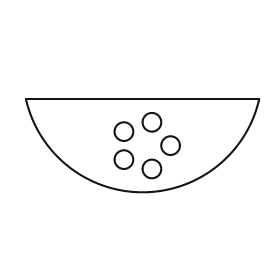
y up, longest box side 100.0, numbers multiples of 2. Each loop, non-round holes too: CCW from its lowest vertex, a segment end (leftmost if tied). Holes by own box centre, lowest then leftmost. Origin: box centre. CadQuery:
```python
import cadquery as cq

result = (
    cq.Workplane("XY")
    .moveTo(-50.0, 20.0)
    .threePointArc((0.0, -20.0), (50.0, 20.0))
    .close()
    .moveTo(4.0, -10.0)
    .circle(4.0)
    .moveTo(-8.0, -6.0)
    .circle(4.0)
    .moveTo(12.0, 0.0)
    .circle(4.0)
    .moveTo(-8.0, 6.0)
    .circle(4.0)
    .moveTo(4.0, 10.0)
    .circle(4.0)
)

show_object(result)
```